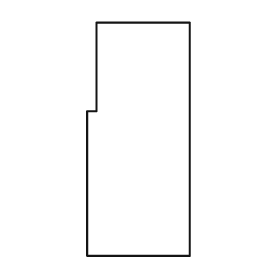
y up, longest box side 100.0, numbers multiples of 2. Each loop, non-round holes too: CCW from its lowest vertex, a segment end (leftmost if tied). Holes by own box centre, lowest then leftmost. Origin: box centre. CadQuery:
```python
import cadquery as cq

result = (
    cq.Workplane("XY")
    .moveTo(-22.0, -50.0)
    .lineTo(22.0, -50.0)
    .lineTo(22.0, 50.0)
    .lineTo(-18.0, 50.0)
    .lineTo(-18.0, 12.0)
    .lineTo(-22.0, 12.0)
    .close()
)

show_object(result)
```